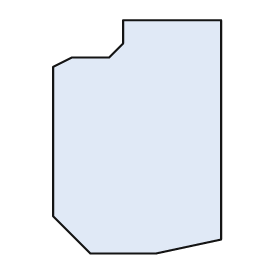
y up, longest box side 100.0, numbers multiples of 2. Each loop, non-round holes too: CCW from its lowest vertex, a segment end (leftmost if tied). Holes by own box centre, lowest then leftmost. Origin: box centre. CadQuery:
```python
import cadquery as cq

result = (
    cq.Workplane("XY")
    .moveTo(-20.0, -50.0)
    .lineTo(8.0, -50.0)
    .lineTo(36.0, -44.0)
    .lineTo(36.0, 50.0)
    .lineTo(-6.0, 50.0)
    .lineTo(-6.0, 40.0)
    .lineTo(-12.0, 34.0)
    .lineTo(-28.0, 34.0)
    .lineTo(-36.0, 30.0)
    .lineTo(-36.0, -34.0)
    .close()
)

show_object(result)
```